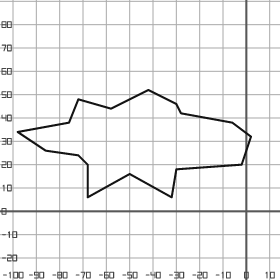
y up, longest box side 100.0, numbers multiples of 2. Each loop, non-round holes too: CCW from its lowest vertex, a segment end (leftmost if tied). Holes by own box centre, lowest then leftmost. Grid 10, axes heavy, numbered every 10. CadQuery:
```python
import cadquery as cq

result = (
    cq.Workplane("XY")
    .moveTo(-68.0, 6.0)
    .lineTo(-50.0, 16.0)
    .lineTo(-32.0, 6.0)
    .lineTo(-30.0, 18.0)
    .lineTo(-2.0, 20.0)
    .lineTo(2.0, 32.0)
    .lineTo(-6.0, 38.0)
    .lineTo(-28.0, 42.0)
    .lineTo(-30.0, 46.0)
    .lineTo(-42.0, 52.0)
    .lineTo(-58.0, 44.0)
    .lineTo(-72.0, 48.0)
    .lineTo(-76.0, 38.0)
    .lineTo(-98.0, 34.0)
    .lineTo(-86.0, 26.0)
    .lineTo(-72.0, 24.0)
    .lineTo(-68.0, 20.0)
    .close()
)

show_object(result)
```